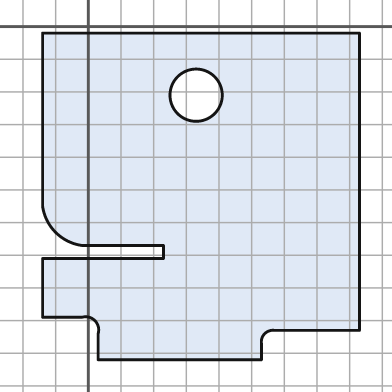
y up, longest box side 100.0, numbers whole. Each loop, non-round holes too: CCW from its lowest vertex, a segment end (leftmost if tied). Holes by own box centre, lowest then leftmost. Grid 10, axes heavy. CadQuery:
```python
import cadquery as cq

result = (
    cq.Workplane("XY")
    .moveTo(3.0, -102.0)
    .lineTo(53.0, -102.0)
    .lineTo(53.0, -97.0)
    .threePointArc((54.0, -94.0), (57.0, -93.0))
    .lineTo(83.0, -93.0)
    .lineTo(83.0, -2.0)
    .lineTo(-14.0, -2.0)
    .lineTo(-14.0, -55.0)
    .threePointArc((-10.0, -63.0), (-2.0, -67.0))
    .lineTo(23.0, -67.0)
    .lineTo(23.0, -71.0)
    .lineTo(-14.0, -71.0)
    .lineTo(-14.0, -89.0)
    .lineTo(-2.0, -89.0)
    .threePointArc((2.0, -90.0), (3.0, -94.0))
    .close()
    .moveTo(33.0, -21.0)
    .circle(8.0)
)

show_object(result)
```